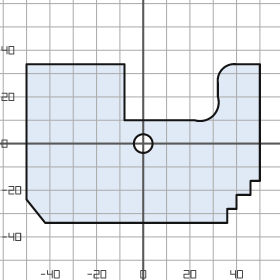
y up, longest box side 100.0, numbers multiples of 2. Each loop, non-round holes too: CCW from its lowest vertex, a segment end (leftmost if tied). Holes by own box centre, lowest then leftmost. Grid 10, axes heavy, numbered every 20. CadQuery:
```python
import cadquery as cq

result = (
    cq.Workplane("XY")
    .moveTo(-42.0, -34.0)
    .lineTo(36.0, -34.0)
    .lineTo(36.0, -28.0)
    .lineTo(40.0, -28.0)
    .lineTo(40.0, -22.0)
    .lineTo(46.0, -22.0)
    .lineTo(46.0, -16.0)
    .lineTo(50.0, -16.0)
    .lineTo(50.0, 34.0)
    .lineTo(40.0, 34.0)
    .threePointArc((34.0, 32.0), (32.0, 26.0))
    .lineTo(32.0, 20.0)
    .threePointArc((30.0, 12.0), (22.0, 10.0))
    .lineTo(-8.0, 10.0)
    .lineTo(-8.0, 34.0)
    .lineTo(-50.0, 34.0)
    .lineTo(-50.0, -24.0)
    .close()
    .moveTo(0.0, 0.0)
    .circle(4.0)
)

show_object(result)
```